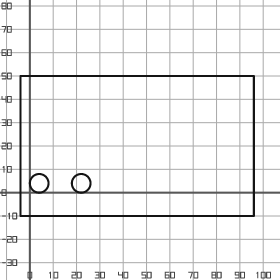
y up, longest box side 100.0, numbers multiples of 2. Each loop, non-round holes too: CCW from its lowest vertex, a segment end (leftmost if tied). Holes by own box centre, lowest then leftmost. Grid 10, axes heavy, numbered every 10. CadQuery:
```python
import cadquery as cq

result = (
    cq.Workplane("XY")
    .moveTo(-4.0, -10.0)
    .lineTo(96.0, -10.0)
    .lineTo(96.0, 50.0)
    .lineTo(-4.0, 50.0)
    .close()
    .moveTo(4.0, 4.0)
    .circle(4.0)
    .moveTo(22.0, 4.0)
    .circle(4.0)
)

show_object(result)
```